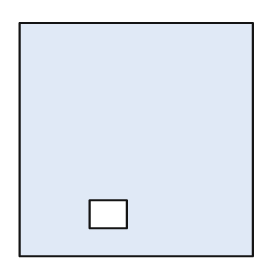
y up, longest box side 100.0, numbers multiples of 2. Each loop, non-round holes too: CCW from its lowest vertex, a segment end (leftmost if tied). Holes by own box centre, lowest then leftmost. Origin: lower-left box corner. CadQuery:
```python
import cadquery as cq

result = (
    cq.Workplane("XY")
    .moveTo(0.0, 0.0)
    .lineTo(100.0, 0.0)
    .lineTo(100.0, 100.0)
    .lineTo(0.0, 100.0)
    .close()
    .moveTo(30.0, 12.0)
    .lineTo(46.0, 12.0)
    .lineTo(46.0, 24.0)
    .lineTo(30.0, 24.0)
    .close()
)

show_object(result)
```